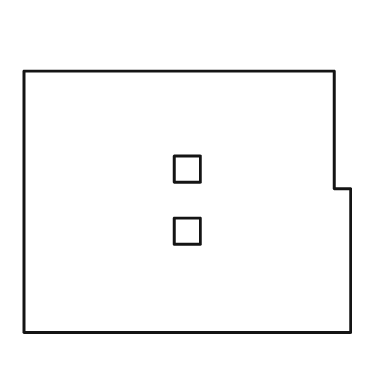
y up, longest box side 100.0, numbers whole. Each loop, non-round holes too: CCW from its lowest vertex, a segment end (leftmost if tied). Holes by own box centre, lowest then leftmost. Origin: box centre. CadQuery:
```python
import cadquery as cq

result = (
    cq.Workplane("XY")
    .moveTo(-50.0, -40.0)
    .lineTo(50.0, -40.0)
    .lineTo(50.0, 4.0)
    .lineTo(45.0, 4.0)
    .lineTo(45.0, 40.0)
    .lineTo(-50.0, 40.0)
    .close()
    .moveTo(-4.0, -13.0)
    .lineTo(4.0, -13.0)
    .lineTo(4.0, -5.0)
    .lineTo(-4.0, -5.0)
    .close()
    .moveTo(-4.0, 6.0)
    .lineTo(4.0, 6.0)
    .lineTo(4.0, 14.0)
    .lineTo(-4.0, 14.0)
    .close()
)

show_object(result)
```